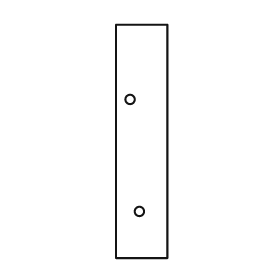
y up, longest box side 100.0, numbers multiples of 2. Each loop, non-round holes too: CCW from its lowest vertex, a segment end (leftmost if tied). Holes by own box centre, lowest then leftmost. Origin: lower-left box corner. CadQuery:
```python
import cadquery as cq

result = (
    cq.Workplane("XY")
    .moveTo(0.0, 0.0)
    .lineTo(22.0, 0.0)
    .lineTo(22.0, 100.0)
    .lineTo(0.0, 100.0)
    .close()
    .moveTo(10.0, 20.0)
    .circle(2.0)
    .moveTo(6.0, 68.0)
    .circle(2.0)
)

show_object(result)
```